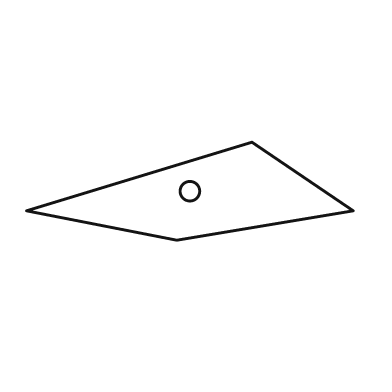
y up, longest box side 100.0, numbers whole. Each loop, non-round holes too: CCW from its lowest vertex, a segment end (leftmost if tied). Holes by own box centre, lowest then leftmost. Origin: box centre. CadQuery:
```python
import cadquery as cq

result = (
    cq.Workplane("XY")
    .moveTo(-4.0, -15.0)
    .lineTo(50.0, -6.0)
    .lineTo(19.0, 15.0)
    .lineTo(-50.0, -6.0)
    .close()
    .moveTo(0.0, 0.0)
    .circle(3.0)
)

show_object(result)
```